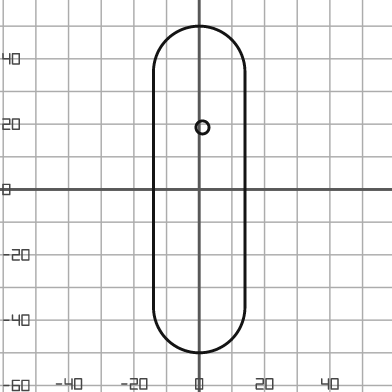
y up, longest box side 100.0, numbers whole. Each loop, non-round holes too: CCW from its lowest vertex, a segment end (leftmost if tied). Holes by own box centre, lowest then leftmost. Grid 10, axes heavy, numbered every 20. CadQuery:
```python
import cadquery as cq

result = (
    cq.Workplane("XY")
    .moveTo(-14.0, -36.0)
    .threePointArc((0.0, -50.0), (14.0, -36.0))
    .lineTo(14.0, 36.0)
    .threePointArc((0.0, 50.0), (-14.0, 36.0))
    .close()
    .moveTo(1.0, 19.0)
    .circle(2.0)
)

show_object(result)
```